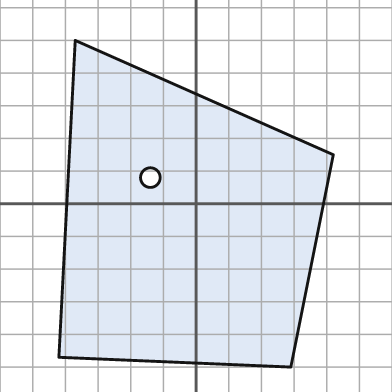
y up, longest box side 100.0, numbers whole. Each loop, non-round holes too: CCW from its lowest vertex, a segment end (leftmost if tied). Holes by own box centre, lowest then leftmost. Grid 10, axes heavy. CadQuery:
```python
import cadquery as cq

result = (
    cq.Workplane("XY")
    .moveTo(29.0, -50.0)
    .lineTo(42.0, 15.0)
    .lineTo(-37.0, 50.0)
    .lineTo(-42.0, -47.0)
    .close()
    .moveTo(-14.0, 8.0)
    .circle(3.0)
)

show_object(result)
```